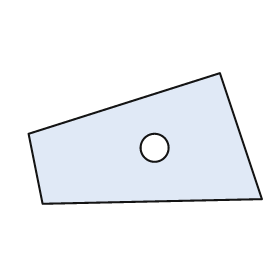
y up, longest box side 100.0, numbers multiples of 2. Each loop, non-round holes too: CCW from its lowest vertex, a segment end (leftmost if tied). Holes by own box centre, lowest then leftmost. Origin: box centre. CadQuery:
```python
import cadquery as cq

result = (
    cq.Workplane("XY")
    .moveTo(-44.0, -28.0)
    .lineTo(50.0, -26.0)
    .lineTo(32.0, 28.0)
    .lineTo(-50.0, 2.0)
    .close()
    .moveTo(4.0, -4.0)
    .circle(6.0)
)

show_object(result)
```